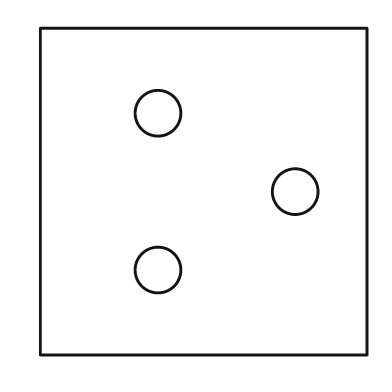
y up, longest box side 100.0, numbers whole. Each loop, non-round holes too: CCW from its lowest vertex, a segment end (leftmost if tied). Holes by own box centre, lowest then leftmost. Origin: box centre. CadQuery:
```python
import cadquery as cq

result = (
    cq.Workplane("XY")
    .moveTo(-50.0, -50.0)
    .lineTo(50.0, -50.0)
    .lineTo(50.0, 50.0)
    .lineTo(-50.0, 50.0)
    .close()
    .moveTo(-14.0, -24.0)
    .circle(7.0)
    .moveTo(28.0, 0.0)
    .circle(7.0)
    .moveTo(-14.0, 24.0)
    .circle(7.0)
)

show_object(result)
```